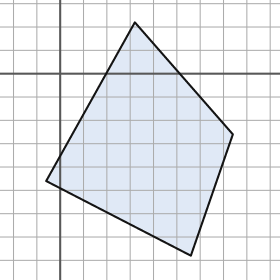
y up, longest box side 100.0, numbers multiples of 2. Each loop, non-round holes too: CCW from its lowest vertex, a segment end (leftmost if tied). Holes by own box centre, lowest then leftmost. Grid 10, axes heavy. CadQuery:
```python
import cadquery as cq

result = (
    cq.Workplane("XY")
    .moveTo(56.0, -78.0)
    .lineTo(74.0, -26.0)
    .lineTo(32.0, 22.0)
    .lineTo(-6.0, -46.0)
    .close()
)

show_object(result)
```